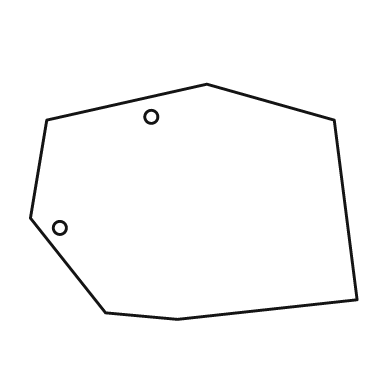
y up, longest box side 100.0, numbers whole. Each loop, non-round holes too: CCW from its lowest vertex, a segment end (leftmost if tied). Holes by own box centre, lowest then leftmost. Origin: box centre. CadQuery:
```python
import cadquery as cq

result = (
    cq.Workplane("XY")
    .moveTo(-5.0, -36.0)
    .lineTo(50.0, -30.0)
    .lineTo(43.0, 25.0)
    .lineTo(4.0, 36.0)
    .lineTo(-45.0, 25.0)
    .lineTo(-50.0, -5.0)
    .lineTo(-27.0, -34.0)
    .close()
    .moveTo(-41.0, -8.0)
    .circle(2.0)
    .moveTo(-13.0, 26.0)
    .circle(2.0)
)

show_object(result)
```